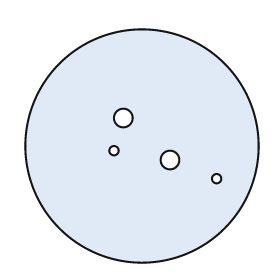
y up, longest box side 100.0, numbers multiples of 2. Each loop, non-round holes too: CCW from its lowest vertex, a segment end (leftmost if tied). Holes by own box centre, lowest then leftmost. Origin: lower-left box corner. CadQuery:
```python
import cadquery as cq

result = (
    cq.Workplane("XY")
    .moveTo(50.0, 50.0)
    .circle(50.0)
    .moveTo(82.0, 36.0)
    .circle(2.0)
    .moveTo(62.0, 44.0)
    .circle(4.0)
    .moveTo(38.0, 48.0)
    .circle(2.0)
    .moveTo(42.0, 62.0)
    .circle(4.0)
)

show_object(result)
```